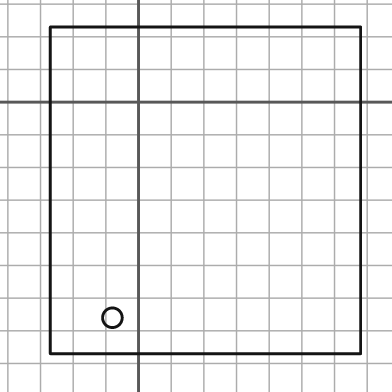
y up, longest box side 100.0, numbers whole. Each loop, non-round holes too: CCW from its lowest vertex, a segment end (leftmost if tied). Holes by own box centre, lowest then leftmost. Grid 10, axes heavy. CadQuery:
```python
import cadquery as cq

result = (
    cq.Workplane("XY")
    .moveTo(-27.0, -77.0)
    .lineTo(68.0, -77.0)
    .lineTo(68.0, 23.0)
    .lineTo(-27.0, 23.0)
    .close()
    .moveTo(-8.0, -66.0)
    .circle(3.0)
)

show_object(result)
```